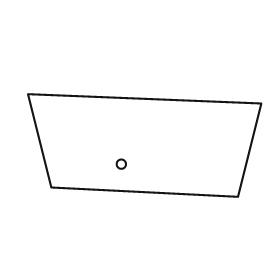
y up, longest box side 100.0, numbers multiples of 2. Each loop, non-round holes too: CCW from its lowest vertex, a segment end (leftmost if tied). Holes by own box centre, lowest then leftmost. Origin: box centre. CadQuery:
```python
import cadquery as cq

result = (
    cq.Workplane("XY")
    .moveTo(40.0, -22.0)
    .lineTo(50.0, 18.0)
    .lineTo(-50.0, 22.0)
    .lineTo(-40.0, -18.0)
    .close()
    .moveTo(-10.0, -8.0)
    .circle(2.0)
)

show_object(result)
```